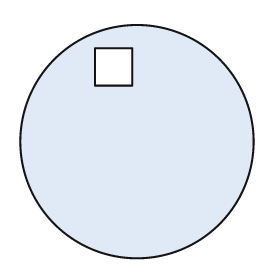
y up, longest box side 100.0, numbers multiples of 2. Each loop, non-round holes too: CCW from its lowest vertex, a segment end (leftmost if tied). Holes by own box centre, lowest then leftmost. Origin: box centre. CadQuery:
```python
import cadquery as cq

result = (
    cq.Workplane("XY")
    .moveTo(0.0, 0.0)
    .circle(50.0)
    .moveTo(-18.0, 24.0)
    .lineTo(-2.0, 24.0)
    .lineTo(-2.0, 40.0)
    .lineTo(-18.0, 40.0)
    .close()
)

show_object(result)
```